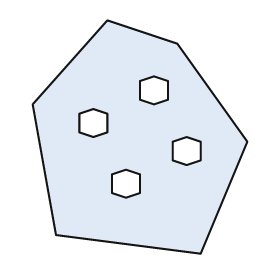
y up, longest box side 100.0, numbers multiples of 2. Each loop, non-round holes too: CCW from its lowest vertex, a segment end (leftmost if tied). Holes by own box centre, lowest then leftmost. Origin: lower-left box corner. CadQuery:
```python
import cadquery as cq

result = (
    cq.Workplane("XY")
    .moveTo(72.0, 0.0)
    .lineTo(92.0, 48.0)
    .lineTo(62.0, 90.0)
    .lineTo(32.0, 100.0)
    .lineTo(0.0, 64.0)
    .lineTo(10.0, 8.0)
    .close()
    .moveTo(40.0, 24.0)
    .lineTo(46.0, 26.0)
    .lineTo(46.0, 34.0)
    .lineTo(40.0, 36.0)
    .lineTo(34.0, 34.0)
    .lineTo(34.0, 26.0)
    .close()
    .moveTo(66.0, 38.0)
    .lineTo(72.0, 40.0)
    .lineTo(72.0, 48.0)
    .lineTo(66.0, 50.0)
    .lineTo(60.0, 48.0)
    .lineTo(60.0, 40.0)
    .close()
    .moveTo(26.0, 50.0)
    .lineTo(32.0, 52.0)
    .lineTo(32.0, 60.0)
    .lineTo(26.0, 62.0)
    .lineTo(20.0, 60.0)
    .lineTo(20.0, 52.0)
    .close()
    .moveTo(52.0, 64.0)
    .lineTo(58.0, 66.0)
    .lineTo(58.0, 74.0)
    .lineTo(52.0, 76.0)
    .lineTo(46.0, 74.0)
    .lineTo(46.0, 66.0)
    .close()
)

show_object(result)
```